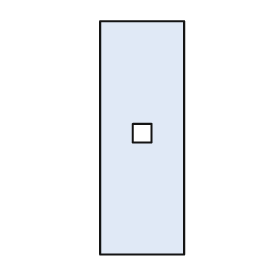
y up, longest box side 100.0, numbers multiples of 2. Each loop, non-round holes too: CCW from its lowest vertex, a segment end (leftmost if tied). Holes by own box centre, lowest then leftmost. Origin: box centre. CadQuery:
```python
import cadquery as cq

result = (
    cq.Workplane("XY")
    .moveTo(-18.0, -50.0)
    .lineTo(18.0, -50.0)
    .lineTo(18.0, 50.0)
    .lineTo(-18.0, 50.0)
    .close()
    .moveTo(-4.0, -2.0)
    .lineTo(4.0, -2.0)
    .lineTo(4.0, 6.0)
    .lineTo(-4.0, 6.0)
    .close()
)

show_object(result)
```